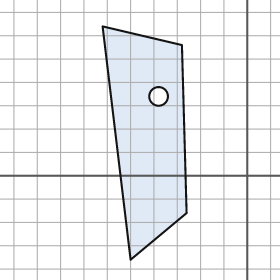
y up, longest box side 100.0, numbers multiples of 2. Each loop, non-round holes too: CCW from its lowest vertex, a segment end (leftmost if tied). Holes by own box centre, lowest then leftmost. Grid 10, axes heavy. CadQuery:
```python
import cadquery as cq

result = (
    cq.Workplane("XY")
    .moveTo(-50.0, -36.0)
    .lineTo(-26.0, -16.0)
    .lineTo(-28.0, 56.0)
    .lineTo(-62.0, 64.0)
    .close()
    .moveTo(-38.0, 34.0)
    .circle(4.0)
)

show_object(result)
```